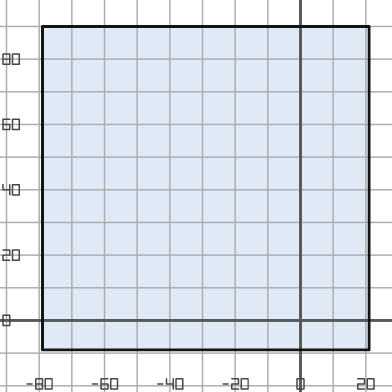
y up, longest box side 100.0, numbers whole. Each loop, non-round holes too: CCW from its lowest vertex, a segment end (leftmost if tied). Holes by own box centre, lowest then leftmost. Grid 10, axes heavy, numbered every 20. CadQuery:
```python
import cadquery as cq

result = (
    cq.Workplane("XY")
    .moveTo(-79.0, -9.0)
    .lineTo(21.0, -9.0)
    .lineTo(21.0, 90.0)
    .lineTo(-79.0, 90.0)
    .close()
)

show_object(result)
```